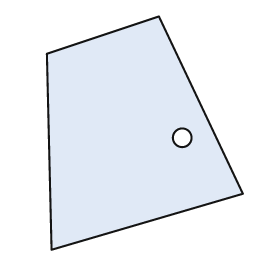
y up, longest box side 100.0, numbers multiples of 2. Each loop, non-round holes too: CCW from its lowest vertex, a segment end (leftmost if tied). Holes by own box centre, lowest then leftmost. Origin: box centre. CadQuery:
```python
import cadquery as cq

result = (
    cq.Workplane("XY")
    .moveTo(-40.0, -50.0)
    .lineTo(42.0, -26.0)
    .lineTo(6.0, 50.0)
    .lineTo(-42.0, 34.0)
    .close()
    .moveTo(16.0, -2.0)
    .circle(4.0)
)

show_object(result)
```